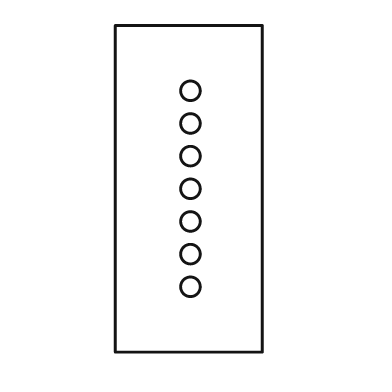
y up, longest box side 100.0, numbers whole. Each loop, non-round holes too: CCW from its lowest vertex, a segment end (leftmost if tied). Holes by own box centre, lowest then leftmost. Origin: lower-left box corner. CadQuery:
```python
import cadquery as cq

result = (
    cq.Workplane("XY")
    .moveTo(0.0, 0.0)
    .lineTo(45.0, 0.0)
    .lineTo(45.0, 100.0)
    .lineTo(0.0, 100.0)
    .close()
    .moveTo(23.0, 20.0)
    .circle(3.0)
    .moveTo(23.0, 30.0)
    .circle(3.0)
    .moveTo(23.0, 40.0)
    .circle(3.0)
    .moveTo(23.0, 50.0)
    .circle(3.0)
    .moveTo(23.0, 60.0)
    .circle(3.0)
    .moveTo(23.0, 70.0)
    .circle(3.0)
    .moveTo(23.0, 80.0)
    .circle(3.0)
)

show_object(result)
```